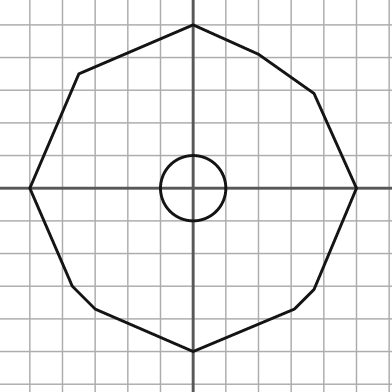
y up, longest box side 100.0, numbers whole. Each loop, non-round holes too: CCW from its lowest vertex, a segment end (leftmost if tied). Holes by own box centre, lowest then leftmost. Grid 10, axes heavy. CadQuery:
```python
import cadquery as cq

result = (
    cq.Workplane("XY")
    .moveTo(0.0, -50.0)
    .lineTo(31.0, -37.0)
    .lineTo(37.0, -31.0)
    .lineTo(50.0, 0.0)
    .lineTo(37.0, 29.0)
    .lineTo(20.0, 41.0)
    .lineTo(0.0, 50.0)
    .lineTo(-35.0, 35.0)
    .lineTo(-50.0, 0.0)
    .lineTo(-37.0, -30.0)
    .lineTo(-30.0, -37.0)
    .close()
    .moveTo(0.0, 0.0)
    .circle(10.0)
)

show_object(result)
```